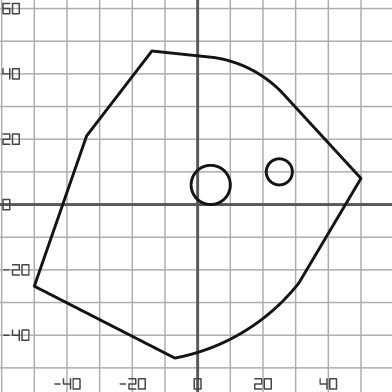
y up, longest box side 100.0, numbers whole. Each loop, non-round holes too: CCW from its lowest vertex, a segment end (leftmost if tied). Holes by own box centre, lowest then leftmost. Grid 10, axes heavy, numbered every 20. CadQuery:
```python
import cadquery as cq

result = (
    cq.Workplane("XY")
    .moveTo(-7.0, -47.0)
    .threePointArc((14.0, -39.0), (31.0, -24.0))
    .lineTo(50.0, 8.0)
    .lineTo(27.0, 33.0)
    .threePointArc((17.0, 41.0), (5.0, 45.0))
    .lineTo(-14.0, 47.0)
    .lineTo(-34.0, 21.0)
    .lineTo(-50.0, -25.0)
    .close()
    .moveTo(4.0, 6.0)
    .circle(6.0)
    .moveTo(25.0, 10.0)
    .circle(4.0)
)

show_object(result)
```